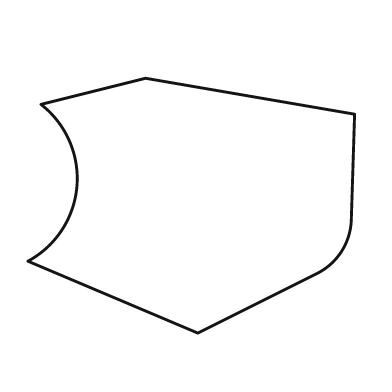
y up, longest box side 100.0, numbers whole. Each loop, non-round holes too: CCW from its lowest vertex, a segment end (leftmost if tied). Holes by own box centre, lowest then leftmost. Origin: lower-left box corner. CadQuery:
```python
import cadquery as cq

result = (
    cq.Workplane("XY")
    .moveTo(52.0, 0.0)
    .lineTo(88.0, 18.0)
    .threePointArc((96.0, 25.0), (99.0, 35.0))
    .lineTo(100.0, 67.0)
    .lineTo(36.0, 78.0)
    .lineTo(4.0, 70.0)
    .threePointArc((15.0, 45.0), (0.0, 22.0))
    .close()
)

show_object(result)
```